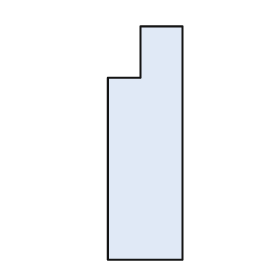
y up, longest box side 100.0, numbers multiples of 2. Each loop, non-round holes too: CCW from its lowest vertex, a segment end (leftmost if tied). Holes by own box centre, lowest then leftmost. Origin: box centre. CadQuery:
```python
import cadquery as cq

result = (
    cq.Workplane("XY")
    .moveTo(-16.0, -50.0)
    .lineTo(16.0, -50.0)
    .lineTo(16.0, 50.0)
    .lineTo(-2.0, 50.0)
    .lineTo(-2.0, 28.0)
    .lineTo(-16.0, 28.0)
    .close()
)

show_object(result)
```